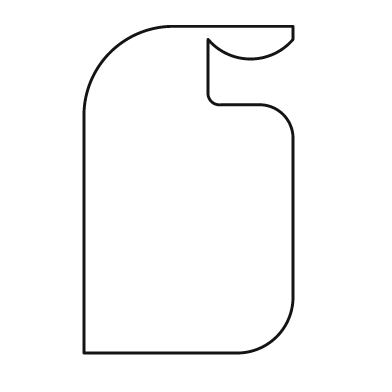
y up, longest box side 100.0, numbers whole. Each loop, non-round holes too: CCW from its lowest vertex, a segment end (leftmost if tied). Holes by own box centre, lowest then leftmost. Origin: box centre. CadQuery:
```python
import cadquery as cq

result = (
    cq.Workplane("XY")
    .moveTo(-32.0, -50.0)
    .lineTo(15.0, -50.0)
    .threePointArc((27.0, -45.0), (32.0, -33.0))
    .lineTo(32.0, 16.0)
    .threePointArc((29.0, 23.0), (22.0, 26.0))
    .lineTo(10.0, 26.0)
    .threePointArc((7.0, 27.0), (6.0, 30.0))
    .lineTo(6.0, 46.0)
    .threePointArc((19.0, 40.0), (32.0, 46.0))
    .lineTo(32.0, 50.0)
    .lineTo(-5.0, 50.0)
    .threePointArc((-24.0, 42.0), (-32.0, 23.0))
    .close()
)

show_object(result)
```